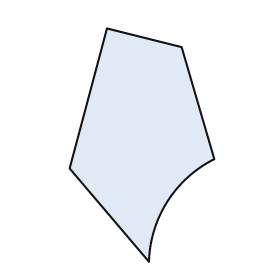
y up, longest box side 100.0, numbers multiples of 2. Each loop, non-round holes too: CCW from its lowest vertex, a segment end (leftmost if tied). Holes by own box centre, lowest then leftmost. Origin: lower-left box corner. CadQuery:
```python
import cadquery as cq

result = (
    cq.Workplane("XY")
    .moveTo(34.0, 0.0)
    .threePointArc((42.0, 26.0), (62.0, 44.0))
    .lineTo(48.0, 92.0)
    .lineTo(16.0, 100.0)
    .lineTo(0.0, 40.0)
    .close()
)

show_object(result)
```